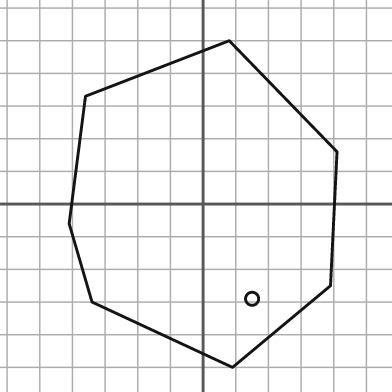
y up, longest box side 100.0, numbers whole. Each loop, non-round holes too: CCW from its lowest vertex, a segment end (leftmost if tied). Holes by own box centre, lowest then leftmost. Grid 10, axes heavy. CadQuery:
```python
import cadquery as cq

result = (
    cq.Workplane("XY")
    .moveTo(9.0, -50.0)
    .lineTo(39.0, -25.0)
    .lineTo(41.0, 16.0)
    .lineTo(8.0, 50.0)
    .lineTo(-36.0, 33.0)
    .lineTo(-41.0, -6.0)
    .lineTo(-34.0, -30.0)
    .close()
    .moveTo(15.0, -29.0)
    .circle(2.0)
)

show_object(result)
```